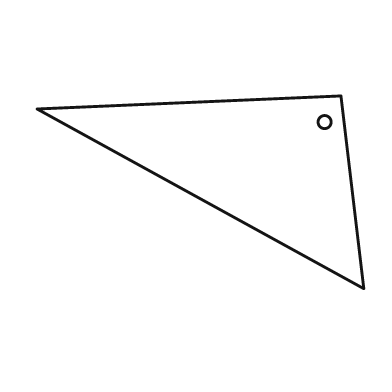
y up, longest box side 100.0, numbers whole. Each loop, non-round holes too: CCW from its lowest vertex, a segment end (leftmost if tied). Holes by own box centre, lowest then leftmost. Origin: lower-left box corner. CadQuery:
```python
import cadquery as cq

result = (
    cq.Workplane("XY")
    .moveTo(100.0, 0.0)
    .lineTo(93.0, 59.0)
    .lineTo(0.0, 55.0)
    .close()
    .moveTo(88.0, 51.0)
    .circle(2.0)
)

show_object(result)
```